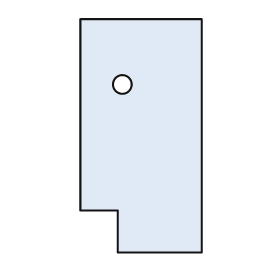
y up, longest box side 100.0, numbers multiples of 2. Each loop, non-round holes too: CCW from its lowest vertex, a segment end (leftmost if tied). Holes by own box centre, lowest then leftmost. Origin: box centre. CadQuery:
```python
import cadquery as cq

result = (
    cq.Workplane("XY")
    .moveTo(-10.0, -50.0)
    .lineTo(26.0, -50.0)
    .lineTo(26.0, 50.0)
    .lineTo(-26.0, 50.0)
    .lineTo(-26.0, -32.0)
    .lineTo(-10.0, -32.0)
    .close()
    .moveTo(-8.0, 22.0)
    .circle(4.0)
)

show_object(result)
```